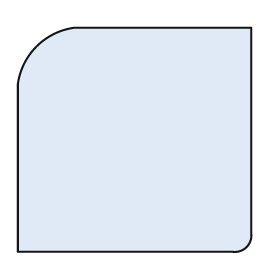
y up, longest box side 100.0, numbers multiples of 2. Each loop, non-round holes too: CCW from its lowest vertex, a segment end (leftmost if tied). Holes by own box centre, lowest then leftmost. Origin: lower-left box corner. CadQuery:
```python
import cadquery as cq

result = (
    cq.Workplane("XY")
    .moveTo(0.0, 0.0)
    .lineTo(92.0, 0.0)
    .threePointArc((98.0, 2.0), (100.0, 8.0))
    .lineTo(100.0, 96.0)
    .lineTo(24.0, 96.0)
    .threePointArc((8.0, 88.0), (0.0, 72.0))
    .close()
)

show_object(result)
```